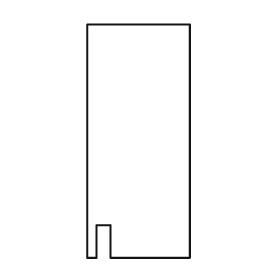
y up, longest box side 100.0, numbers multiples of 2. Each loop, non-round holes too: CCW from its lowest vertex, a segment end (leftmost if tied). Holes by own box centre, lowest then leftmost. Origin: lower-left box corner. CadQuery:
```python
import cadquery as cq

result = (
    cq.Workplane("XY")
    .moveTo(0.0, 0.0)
    .lineTo(4.0, 0.0)
    .lineTo(4.0, 14.0)
    .lineTo(10.0, 14.0)
    .lineTo(10.0, 0.0)
    .lineTo(44.0, 0.0)
    .lineTo(44.0, 100.0)
    .lineTo(0.0, 100.0)
    .close()
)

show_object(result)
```